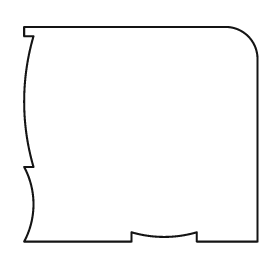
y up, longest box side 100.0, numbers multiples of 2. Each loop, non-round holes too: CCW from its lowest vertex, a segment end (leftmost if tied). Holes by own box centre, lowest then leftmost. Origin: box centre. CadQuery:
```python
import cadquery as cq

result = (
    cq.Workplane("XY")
    .moveTo(-50.0, -46.0)
    .lineTo(-4.0, -46.0)
    .lineTo(-4.0, -42.0)
    .threePointArc((10.0, -44.0), (24.0, -42.0))
    .lineTo(24.0, -46.0)
    .lineTo(50.0, -46.0)
    .lineTo(50.0, 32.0)
    .threePointArc((46.0, 42.0), (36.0, 46.0))
    .lineTo(-50.0, 46.0)
    .lineTo(-50.0, 42.0)
    .lineTo(-46.0, 42.0)
    .threePointArc((-50.0, 14.0), (-46.0, -14.0))
    .lineTo(-50.0, -14.0)
    .threePointArc((-46.0, -30.0), (-50.0, -46.0))
    .close()
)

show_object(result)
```